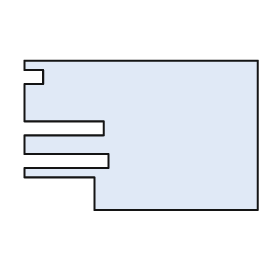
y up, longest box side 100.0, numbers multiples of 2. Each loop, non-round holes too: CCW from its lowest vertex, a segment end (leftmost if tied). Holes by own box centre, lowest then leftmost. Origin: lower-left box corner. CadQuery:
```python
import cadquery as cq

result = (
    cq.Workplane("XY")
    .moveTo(30.0, 0.0)
    .lineTo(100.0, 0.0)
    .lineTo(100.0, 64.0)
    .lineTo(0.0, 64.0)
    .lineTo(0.0, 60.0)
    .lineTo(8.0, 60.0)
    .lineTo(8.0, 54.0)
    .lineTo(0.0, 54.0)
    .lineTo(0.0, 38.0)
    .lineTo(34.0, 38.0)
    .lineTo(34.0, 32.0)
    .lineTo(0.0, 32.0)
    .lineTo(0.0, 24.0)
    .lineTo(36.0, 24.0)
    .lineTo(36.0, 18.0)
    .lineTo(0.0, 18.0)
    .lineTo(0.0, 14.0)
    .lineTo(30.0, 14.0)
    .close()
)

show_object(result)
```